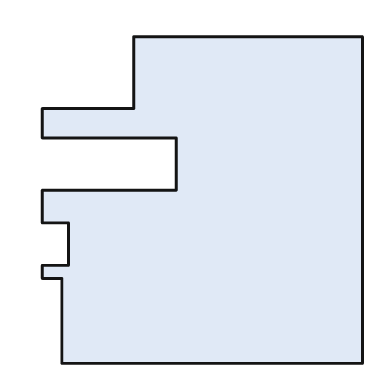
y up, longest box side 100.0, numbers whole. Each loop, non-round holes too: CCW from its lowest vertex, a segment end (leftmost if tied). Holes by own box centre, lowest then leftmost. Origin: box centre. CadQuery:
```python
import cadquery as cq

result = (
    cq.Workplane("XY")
    .moveTo(-43.0, -50.0)
    .lineTo(49.0, -50.0)
    .lineTo(49.0, 50.0)
    .lineTo(-21.0, 50.0)
    .lineTo(-21.0, 28.0)
    .lineTo(-49.0, 28.0)
    .lineTo(-49.0, 19.0)
    .lineTo(-8.0, 19.0)
    .lineTo(-8.0, 3.0)
    .lineTo(-49.0, 3.0)
    .lineTo(-49.0, -7.0)
    .lineTo(-41.0, -7.0)
    .lineTo(-41.0, -20.0)
    .lineTo(-49.0, -20.0)
    .lineTo(-49.0, -24.0)
    .lineTo(-43.0, -24.0)
    .close()
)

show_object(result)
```